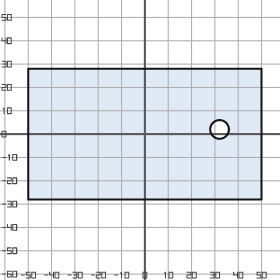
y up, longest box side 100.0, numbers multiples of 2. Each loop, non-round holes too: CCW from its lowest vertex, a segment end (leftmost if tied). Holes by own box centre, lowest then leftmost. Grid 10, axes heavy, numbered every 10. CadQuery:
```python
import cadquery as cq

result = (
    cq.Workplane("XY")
    .moveTo(-50.0, -28.0)
    .lineTo(50.0, -28.0)
    .lineTo(50.0, 28.0)
    .lineTo(-50.0, 28.0)
    .close()
    .moveTo(32.0, 2.0)
    .circle(4.0)
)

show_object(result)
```